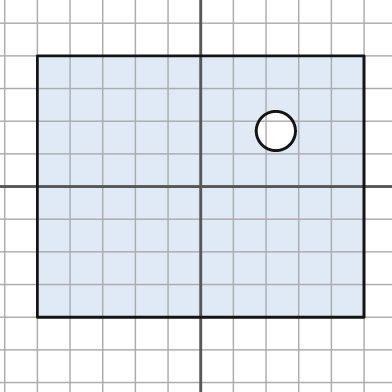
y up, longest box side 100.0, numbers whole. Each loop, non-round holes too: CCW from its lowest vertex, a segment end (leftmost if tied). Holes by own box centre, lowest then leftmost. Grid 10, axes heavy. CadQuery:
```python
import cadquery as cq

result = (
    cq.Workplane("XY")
    .moveTo(-50.0, -40.0)
    .lineTo(50.0, -40.0)
    .lineTo(50.0, 40.0)
    .lineTo(-50.0, 40.0)
    .close()
    .moveTo(23.0, 17.0)
    .circle(6.0)
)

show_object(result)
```